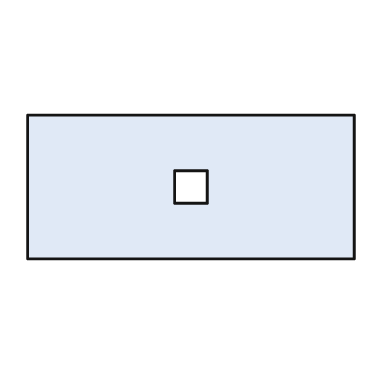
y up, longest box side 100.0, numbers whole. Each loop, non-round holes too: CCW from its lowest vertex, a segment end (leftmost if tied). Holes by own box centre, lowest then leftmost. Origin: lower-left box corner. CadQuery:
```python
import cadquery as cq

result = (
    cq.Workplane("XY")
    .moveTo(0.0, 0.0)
    .lineTo(100.0, 0.0)
    .lineTo(100.0, 44.0)
    .lineTo(0.0, 44.0)
    .close()
    .moveTo(45.0, 17.0)
    .lineTo(55.0, 17.0)
    .lineTo(55.0, 27.0)
    .lineTo(45.0, 27.0)
    .close()
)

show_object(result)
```